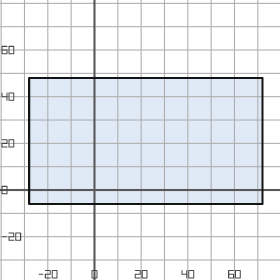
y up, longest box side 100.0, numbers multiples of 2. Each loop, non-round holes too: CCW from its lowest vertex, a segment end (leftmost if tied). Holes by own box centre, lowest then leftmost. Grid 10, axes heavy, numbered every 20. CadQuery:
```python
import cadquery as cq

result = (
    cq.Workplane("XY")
    .moveTo(-28.0, -6.0)
    .lineTo(72.0, -6.0)
    .lineTo(72.0, 48.0)
    .lineTo(-28.0, 48.0)
    .close()
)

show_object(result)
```